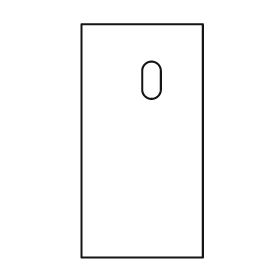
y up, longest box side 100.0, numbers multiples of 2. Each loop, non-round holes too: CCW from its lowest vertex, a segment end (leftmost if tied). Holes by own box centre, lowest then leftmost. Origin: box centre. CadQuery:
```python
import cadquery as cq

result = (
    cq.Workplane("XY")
    .moveTo(-26.0, -50.0)
    .lineTo(26.0, -50.0)
    .lineTo(26.0, 50.0)
    .lineTo(-26.0, 50.0)
    .close()
    .moveTo(0.0, 22.0)
    .threePointArc((4.0, 18.0), (8.0, 22.0))
    .lineTo(8.0, 30.0)
    .threePointArc((4.0, 34.0), (0.0, 30.0))
    .close()
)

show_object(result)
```